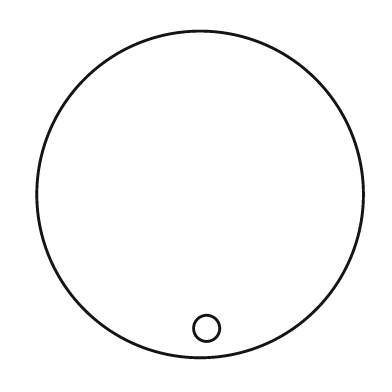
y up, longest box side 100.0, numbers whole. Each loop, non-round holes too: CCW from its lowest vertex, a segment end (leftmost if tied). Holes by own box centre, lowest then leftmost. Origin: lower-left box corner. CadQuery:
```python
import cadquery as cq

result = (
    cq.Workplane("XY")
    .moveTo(50.0, 50.0)
    .circle(50.0)
    .moveTo(52.0, 9.0)
    .circle(4.0)
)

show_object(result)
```